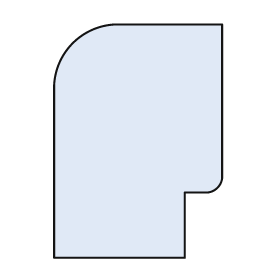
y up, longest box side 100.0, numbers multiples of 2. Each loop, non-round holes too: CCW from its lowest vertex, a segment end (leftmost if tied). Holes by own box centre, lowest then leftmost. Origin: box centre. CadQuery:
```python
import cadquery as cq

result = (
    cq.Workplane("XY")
    .moveTo(-36.0, -50.0)
    .lineTo(20.0, -50.0)
    .lineTo(20.0, -22.0)
    .lineTo(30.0, -22.0)
    .threePointArc((34.0, -20.0), (36.0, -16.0))
    .lineTo(36.0, 50.0)
    .lineTo(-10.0, 50.0)
    .threePointArc((-28.0, 42.0), (-36.0, 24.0))
    .close()
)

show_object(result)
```